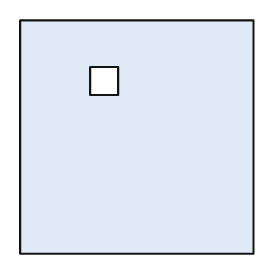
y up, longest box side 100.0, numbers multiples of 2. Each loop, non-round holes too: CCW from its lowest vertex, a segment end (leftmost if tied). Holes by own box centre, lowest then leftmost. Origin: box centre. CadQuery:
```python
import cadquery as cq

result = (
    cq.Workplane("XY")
    .moveTo(-50.0, -50.0)
    .lineTo(50.0, -50.0)
    .lineTo(50.0, 50.0)
    .lineTo(-50.0, 50.0)
    .close()
    .moveTo(-20.0, 18.0)
    .lineTo(-8.0, 18.0)
    .lineTo(-8.0, 30.0)
    .lineTo(-20.0, 30.0)
    .close()
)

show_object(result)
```